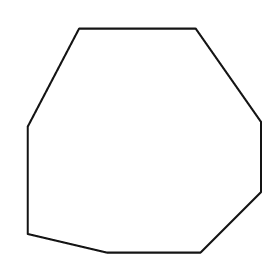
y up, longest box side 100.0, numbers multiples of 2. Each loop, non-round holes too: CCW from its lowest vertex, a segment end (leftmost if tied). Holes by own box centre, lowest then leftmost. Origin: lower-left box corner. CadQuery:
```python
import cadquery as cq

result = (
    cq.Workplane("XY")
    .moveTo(34.0, 0.0)
    .lineTo(74.0, 0.0)
    .lineTo(100.0, 26.0)
    .lineTo(100.0, 56.0)
    .lineTo(72.0, 96.0)
    .lineTo(22.0, 96.0)
    .lineTo(0.0, 54.0)
    .lineTo(0.0, 8.0)
    .close()
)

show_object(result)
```